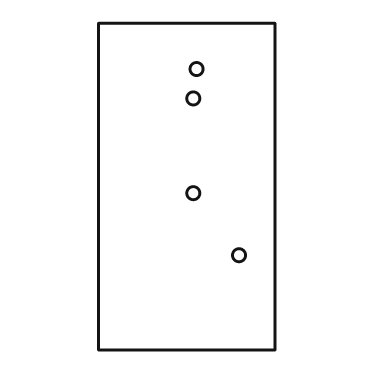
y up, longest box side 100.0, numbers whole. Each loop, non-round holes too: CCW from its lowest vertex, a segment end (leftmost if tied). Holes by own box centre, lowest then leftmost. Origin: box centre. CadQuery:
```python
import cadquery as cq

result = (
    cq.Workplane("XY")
    .moveTo(-27.0, -50.0)
    .lineTo(27.0, -50.0)
    .lineTo(27.0, 50.0)
    .lineTo(-27.0, 50.0)
    .close()
    .moveTo(16.0, -21.0)
    .circle(2.0)
    .moveTo(2.0, -2.0)
    .circle(2.0)
    .moveTo(2.0, 27.0)
    .circle(2.0)
    .moveTo(3.0, 36.0)
    .circle(2.0)
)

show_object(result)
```